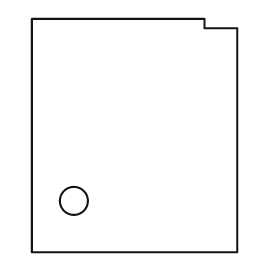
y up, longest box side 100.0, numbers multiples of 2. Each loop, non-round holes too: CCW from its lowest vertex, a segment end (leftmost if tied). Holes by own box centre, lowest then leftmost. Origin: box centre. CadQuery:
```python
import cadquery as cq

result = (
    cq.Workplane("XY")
    .moveTo(-44.0, -50.0)
    .lineTo(44.0, -50.0)
    .lineTo(44.0, 46.0)
    .lineTo(30.0, 46.0)
    .lineTo(30.0, 50.0)
    .lineTo(-44.0, 50.0)
    .close()
    .moveTo(-26.0, -28.0)
    .circle(6.0)
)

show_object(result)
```